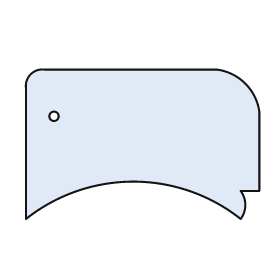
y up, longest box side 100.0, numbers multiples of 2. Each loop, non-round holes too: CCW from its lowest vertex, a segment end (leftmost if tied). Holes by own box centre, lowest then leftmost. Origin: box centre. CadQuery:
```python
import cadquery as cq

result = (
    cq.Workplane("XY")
    .moveTo(-50.0, -32.0)
    .threePointArc((-4.0, -16.0), (42.0, -32.0))
    .threePointArc((44.0, -26.0), (42.0, -20.0))
    .lineTo(50.0, -20.0)
    .lineTo(50.0, 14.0)
    .threePointArc((44.0, 26.0), (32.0, 32.0))
    .lineTo(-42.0, 32.0)
    .threePointArc((-48.0, 30.0), (-50.0, 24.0))
    .close()
    .moveTo(-38.0, 12.0)
    .circle(2.0)
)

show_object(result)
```